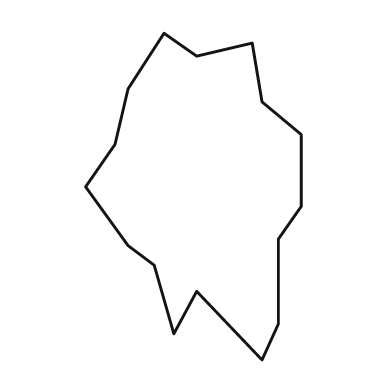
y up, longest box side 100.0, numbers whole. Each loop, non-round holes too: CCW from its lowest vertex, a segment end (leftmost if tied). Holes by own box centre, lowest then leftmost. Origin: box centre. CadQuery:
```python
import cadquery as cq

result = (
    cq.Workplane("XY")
    .moveTo(21.0, -50.0)
    .lineTo(26.0, -39.0)
    .lineTo(26.0, -13.0)
    .lineTo(33.0, -3.0)
    .lineTo(33.0, 19.0)
    .lineTo(21.0, 29.0)
    .lineTo(18.0, 47.0)
    .lineTo(1.0, 43.0)
    .lineTo(-9.0, 50.0)
    .lineTo(-20.0, 33.0)
    .lineTo(-24.0, 16.0)
    .lineTo(-33.0, 3.0)
    .lineTo(-20.0, -15.0)
    .lineTo(-12.0, -21.0)
    .lineTo(-6.0, -42.0)
    .lineTo(1.0, -29.0)
    .close()
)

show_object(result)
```